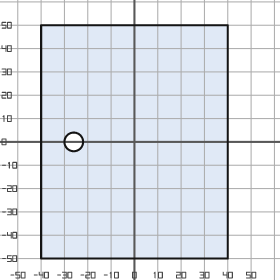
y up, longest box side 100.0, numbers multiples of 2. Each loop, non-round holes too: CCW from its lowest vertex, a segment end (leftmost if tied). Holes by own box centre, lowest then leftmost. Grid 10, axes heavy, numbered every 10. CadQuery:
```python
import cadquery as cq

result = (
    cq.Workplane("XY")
    .moveTo(-40.0, -50.0)
    .lineTo(40.0, -50.0)
    .lineTo(40.0, 50.0)
    .lineTo(-40.0, 50.0)
    .close()
    .moveTo(-26.0, 0.0)
    .circle(4.0)
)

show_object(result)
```